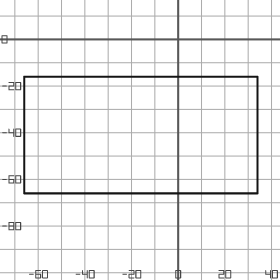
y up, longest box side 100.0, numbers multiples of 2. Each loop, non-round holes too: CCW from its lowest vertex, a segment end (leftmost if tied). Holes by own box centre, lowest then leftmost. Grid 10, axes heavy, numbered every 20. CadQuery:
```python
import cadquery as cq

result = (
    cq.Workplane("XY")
    .moveTo(-66.0, -66.0)
    .lineTo(34.0, -66.0)
    .lineTo(34.0, -16.0)
    .lineTo(-66.0, -16.0)
    .close()
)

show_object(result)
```